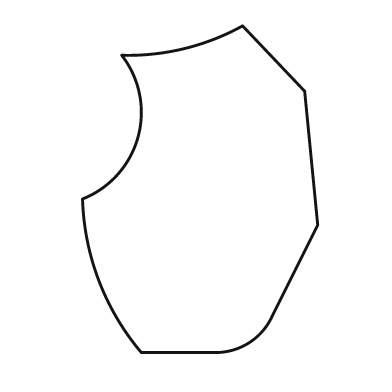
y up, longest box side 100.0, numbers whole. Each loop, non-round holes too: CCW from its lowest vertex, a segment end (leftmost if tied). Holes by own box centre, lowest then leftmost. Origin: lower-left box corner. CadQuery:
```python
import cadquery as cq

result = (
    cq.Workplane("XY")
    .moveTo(18.0, 0.0)
    .lineTo(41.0, 0.0)
    .threePointArc((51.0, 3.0), (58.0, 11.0))
    .lineTo(72.0, 39.0)
    .lineTo(68.0, 80.0)
    .lineTo(49.0, 100.0)
    .threePointArc((31.0, 93.0), (12.0, 91.0))
    .threePointArc((17.0, 66.0), (0.0, 47.0))
    .threePointArc((5.0, 22.0), (18.0, 0.0))
    .close()
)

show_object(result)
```